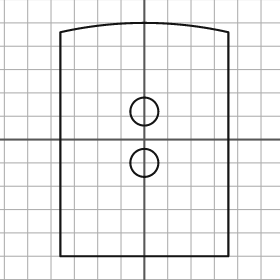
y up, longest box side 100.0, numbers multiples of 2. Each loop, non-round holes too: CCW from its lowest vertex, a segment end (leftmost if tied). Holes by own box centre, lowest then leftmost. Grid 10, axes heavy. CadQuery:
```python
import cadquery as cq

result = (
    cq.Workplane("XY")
    .moveTo(-36.0, -50.0)
    .lineTo(36.0, -50.0)
    .lineTo(36.0, 46.0)
    .threePointArc((0.0, 50.0), (-36.0, 46.0))
    .close()
    .moveTo(0.0, -10.0)
    .circle(6.0)
    .moveTo(0.0, 12.0)
    .circle(6.0)
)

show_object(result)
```